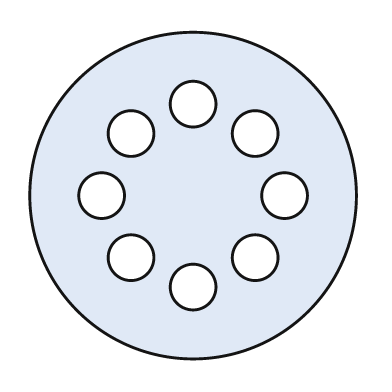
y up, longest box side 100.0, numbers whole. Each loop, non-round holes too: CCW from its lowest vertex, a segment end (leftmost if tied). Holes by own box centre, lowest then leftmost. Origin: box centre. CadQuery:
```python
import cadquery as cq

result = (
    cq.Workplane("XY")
    .moveTo(0.0, 0.0)
    .circle(50.0)
    .moveTo(0.0, -28.0)
    .circle(7.0)
    .moveTo(-19.0, -19.0)
    .circle(7.0)
    .moveTo(19.0, -19.0)
    .circle(7.0)
    .moveTo(-28.0, 0.0)
    .circle(7.0)
    .moveTo(28.0, 0.0)
    .circle(7.0)
    .moveTo(-19.0, 19.0)
    .circle(7.0)
    .moveTo(19.0, 19.0)
    .circle(7.0)
    .moveTo(0.0, 28.0)
    .circle(7.0)
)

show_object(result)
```